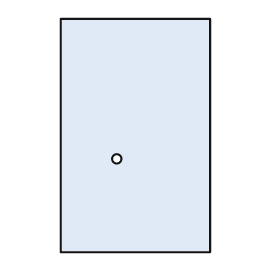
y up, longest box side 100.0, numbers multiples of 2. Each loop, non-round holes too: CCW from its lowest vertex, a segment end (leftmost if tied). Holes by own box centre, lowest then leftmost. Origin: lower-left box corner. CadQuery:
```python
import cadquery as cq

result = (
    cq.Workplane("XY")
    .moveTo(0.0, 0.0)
    .lineTo(64.0, 0.0)
    .lineTo(64.0, 100.0)
    .lineTo(0.0, 100.0)
    .close()
    .moveTo(24.0, 40.0)
    .circle(2.0)
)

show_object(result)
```